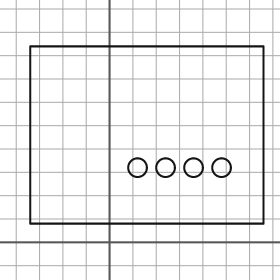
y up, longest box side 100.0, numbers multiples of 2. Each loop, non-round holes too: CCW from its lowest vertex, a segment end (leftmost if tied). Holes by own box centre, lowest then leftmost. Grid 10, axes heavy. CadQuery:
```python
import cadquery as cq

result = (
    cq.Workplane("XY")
    .moveTo(-34.0, 8.0)
    .lineTo(66.0, 8.0)
    .lineTo(66.0, 84.0)
    .lineTo(-34.0, 84.0)
    .close()
    .moveTo(12.0, 32.0)
    .circle(4.0)
    .moveTo(24.0, 32.0)
    .circle(4.0)
    .moveTo(36.0, 32.0)
    .circle(4.0)
    .moveTo(48.0, 32.0)
    .circle(4.0)
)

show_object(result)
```